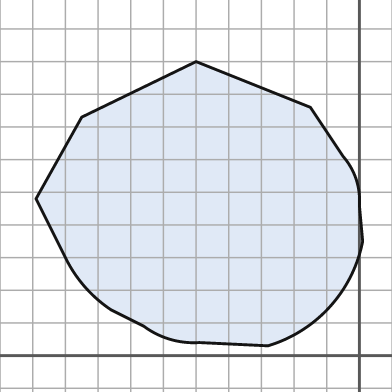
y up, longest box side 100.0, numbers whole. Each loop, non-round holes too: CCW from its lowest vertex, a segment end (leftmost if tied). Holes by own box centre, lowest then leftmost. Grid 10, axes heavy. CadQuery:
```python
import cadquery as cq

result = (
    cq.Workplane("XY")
    .moveTo(-28.0, 3.0)
    .threePointArc((-9.0, 15.0), (1.0, 35.0))
    .lineTo(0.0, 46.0)
    .threePointArc((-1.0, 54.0), (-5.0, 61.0))
    .lineTo(-15.0, 76.0)
    .lineTo(-50.0, 90.0)
    .lineTo(-85.0, 73.0)
    .lineTo(-99.0, 48.0)
    .lineTo(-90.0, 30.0)
    .threePointArc((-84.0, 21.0), (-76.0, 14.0))
    .lineTo(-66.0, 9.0)
    .threePointArc((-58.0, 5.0), (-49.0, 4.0))
    .close()
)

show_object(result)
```